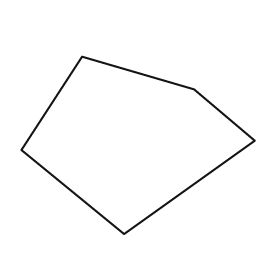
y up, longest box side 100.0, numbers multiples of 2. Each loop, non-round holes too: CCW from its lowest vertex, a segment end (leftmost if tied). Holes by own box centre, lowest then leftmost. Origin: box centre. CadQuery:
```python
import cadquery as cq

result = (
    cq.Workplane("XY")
    .moveTo(-6.0, -38.0)
    .lineTo(50.0, 2.0)
    .lineTo(24.0, 24.0)
    .lineTo(-24.0, 38.0)
    .lineTo(-50.0, -2.0)
    .close()
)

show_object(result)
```